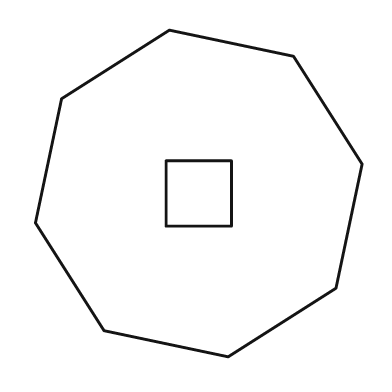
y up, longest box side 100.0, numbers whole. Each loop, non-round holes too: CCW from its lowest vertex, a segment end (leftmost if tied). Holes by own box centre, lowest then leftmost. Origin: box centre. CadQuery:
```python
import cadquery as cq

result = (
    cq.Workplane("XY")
    .moveTo(9.0, -50.0)
    .lineTo(42.0, -29.0)
    .lineTo(50.0, 9.0)
    .lineTo(29.0, 42.0)
    .lineTo(-9.0, 50.0)
    .lineTo(-42.0, 29.0)
    .lineTo(-50.0, -9.0)
    .lineTo(-29.0, -42.0)
    .close()
    .moveTo(-10.0, -10.0)
    .lineTo(10.0, -10.0)
    .lineTo(10.0, 10.0)
    .lineTo(-10.0, 10.0)
    .close()
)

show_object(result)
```